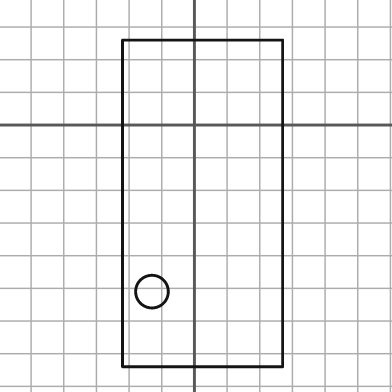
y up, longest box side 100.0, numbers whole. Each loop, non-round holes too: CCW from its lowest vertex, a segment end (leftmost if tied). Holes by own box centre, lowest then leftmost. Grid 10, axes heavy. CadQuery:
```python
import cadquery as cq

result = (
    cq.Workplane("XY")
    .moveTo(-22.0, -74.0)
    .lineTo(27.0, -74.0)
    .lineTo(27.0, 26.0)
    .lineTo(-22.0, 26.0)
    .close()
    .moveTo(-13.0, -51.0)
    .circle(5.0)
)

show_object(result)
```